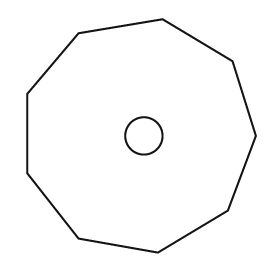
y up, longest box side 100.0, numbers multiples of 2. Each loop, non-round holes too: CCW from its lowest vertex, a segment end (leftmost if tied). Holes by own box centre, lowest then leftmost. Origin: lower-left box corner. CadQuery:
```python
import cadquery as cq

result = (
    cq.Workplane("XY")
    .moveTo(56.0, 0.0)
    .lineTo(86.0, 18.0)
    .lineTo(98.0, 50.0)
    .lineTo(88.0, 82.0)
    .lineTo(58.0, 100.0)
    .lineTo(22.0, 94.0)
    .lineTo(0.0, 68.0)
    .lineTo(0.0, 34.0)
    .lineTo(22.0, 6.0)
    .close()
    .moveTo(50.0, 50.0)
    .circle(8.0)
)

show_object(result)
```